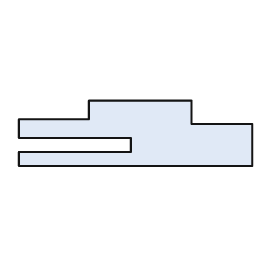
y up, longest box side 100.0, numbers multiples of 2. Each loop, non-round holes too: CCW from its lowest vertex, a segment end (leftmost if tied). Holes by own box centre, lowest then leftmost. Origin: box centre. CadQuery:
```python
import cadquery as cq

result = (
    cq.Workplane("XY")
    .moveTo(-50.0, -14.0)
    .lineTo(50.0, -14.0)
    .lineTo(50.0, 4.0)
    .lineTo(24.0, 4.0)
    .lineTo(24.0, 14.0)
    .lineTo(-20.0, 14.0)
    .lineTo(-20.0, 6.0)
    .lineTo(-50.0, 6.0)
    .lineTo(-50.0, -2.0)
    .lineTo(-2.0, -2.0)
    .lineTo(-2.0, -8.0)
    .lineTo(-50.0, -8.0)
    .close()
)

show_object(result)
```